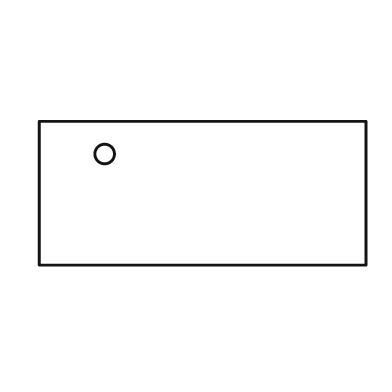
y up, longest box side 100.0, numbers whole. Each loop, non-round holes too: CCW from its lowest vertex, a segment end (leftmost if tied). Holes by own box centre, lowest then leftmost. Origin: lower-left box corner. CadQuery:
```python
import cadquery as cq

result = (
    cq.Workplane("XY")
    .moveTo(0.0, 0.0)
    .lineTo(100.0, 0.0)
    .lineTo(100.0, 44.0)
    .lineTo(0.0, 44.0)
    .close()
    .moveTo(20.0, 34.0)
    .circle(3.0)
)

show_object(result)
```